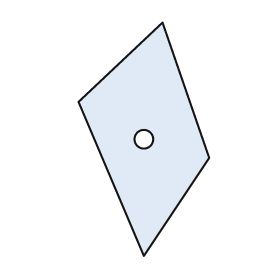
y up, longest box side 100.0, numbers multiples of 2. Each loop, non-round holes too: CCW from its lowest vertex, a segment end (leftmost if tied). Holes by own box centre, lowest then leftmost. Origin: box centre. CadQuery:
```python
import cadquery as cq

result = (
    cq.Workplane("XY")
    .moveTo(0.0, -50.0)
    .lineTo(28.0, -8.0)
    .lineTo(8.0, 50.0)
    .lineTo(-28.0, 16.0)
    .close()
    .moveTo(0.0, 0.0)
    .circle(4.0)
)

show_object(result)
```